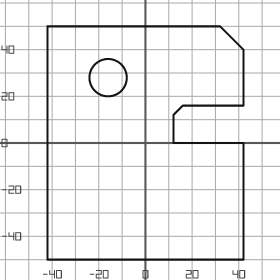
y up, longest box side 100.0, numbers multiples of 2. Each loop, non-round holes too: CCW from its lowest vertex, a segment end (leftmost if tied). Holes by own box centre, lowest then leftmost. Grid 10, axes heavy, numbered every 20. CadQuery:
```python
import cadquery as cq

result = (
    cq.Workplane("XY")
    .moveTo(-42.0, -50.0)
    .lineTo(42.0, -50.0)
    .lineTo(42.0, 0.0)
    .lineTo(12.0, 0.0)
    .lineTo(12.0, 12.0)
    .lineTo(16.0, 16.0)
    .lineTo(42.0, 16.0)
    .lineTo(42.0, 40.0)
    .lineTo(32.0, 50.0)
    .lineTo(-42.0, 50.0)
    .close()
    .moveTo(-16.0, 28.0)
    .circle(8.0)
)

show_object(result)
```